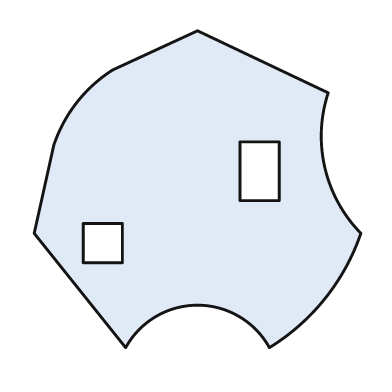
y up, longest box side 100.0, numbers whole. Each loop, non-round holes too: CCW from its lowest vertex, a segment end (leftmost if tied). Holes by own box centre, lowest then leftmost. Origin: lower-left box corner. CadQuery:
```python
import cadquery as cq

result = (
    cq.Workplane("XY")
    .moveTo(28.0, 0.0)
    .threePointArc((50.0, 13.0), (72.0, 0.0))
    .threePointArc((89.0, 15.0), (100.0, 35.0))
    .threePointArc((89.0, 55.0), (90.0, 78.0))
    .lineTo(50.0, 97.0)
    .lineTo(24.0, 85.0)
    .threePointArc((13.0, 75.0), (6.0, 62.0))
    .lineTo(0.0, 35.0)
    .close()
    .moveTo(15.0, 26.0)
    .lineTo(27.0, 26.0)
    .lineTo(27.0, 38.0)
    .lineTo(15.0, 38.0)
    .close()
    .moveTo(63.0, 45.0)
    .lineTo(75.0, 45.0)
    .lineTo(75.0, 63.0)
    .lineTo(63.0, 63.0)
    .close()
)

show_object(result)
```